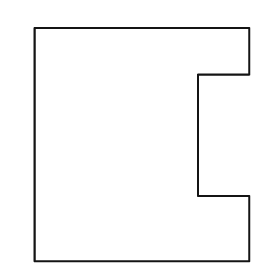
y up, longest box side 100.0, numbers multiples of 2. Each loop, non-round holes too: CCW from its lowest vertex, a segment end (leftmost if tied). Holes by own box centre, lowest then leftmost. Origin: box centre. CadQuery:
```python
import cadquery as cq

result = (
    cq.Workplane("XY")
    .moveTo(-46.0, -50.0)
    .lineTo(46.0, -50.0)
    .lineTo(46.0, -22.0)
    .lineTo(24.0, -22.0)
    .lineTo(24.0, 30.0)
    .lineTo(46.0, 30.0)
    .lineTo(46.0, 50.0)
    .lineTo(-46.0, 50.0)
    .close()
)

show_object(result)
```